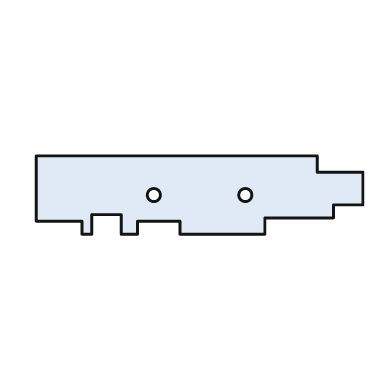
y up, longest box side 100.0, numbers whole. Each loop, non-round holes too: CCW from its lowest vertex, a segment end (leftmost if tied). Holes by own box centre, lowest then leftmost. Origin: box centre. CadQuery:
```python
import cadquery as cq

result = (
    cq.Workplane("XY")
    .moveTo(-36.0, -12.0)
    .lineTo(-33.0, -12.0)
    .lineTo(-33.0, -6.0)
    .lineTo(-24.0, -6.0)
    .lineTo(-24.0, -12.0)
    .lineTo(-19.0, -12.0)
    .lineTo(-19.0, -8.0)
    .lineTo(-6.0, -8.0)
    .lineTo(-6.0, -12.0)
    .lineTo(20.0, -12.0)
    .lineTo(20.0, -7.0)
    .lineTo(41.0, -7.0)
    .lineTo(41.0, -3.0)
    .lineTo(50.0, -3.0)
    .lineTo(50.0, 7.0)
    .lineTo(36.0, 7.0)
    .lineTo(36.0, 12.0)
    .lineTo(-50.0, 12.0)
    .lineTo(-50.0, -8.0)
    .lineTo(-36.0, -8.0)
    .close()
    .moveTo(-14.0, 0.0)
    .circle(2.0)
    .moveTo(14.0, 0.0)
    .circle(2.0)
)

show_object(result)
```